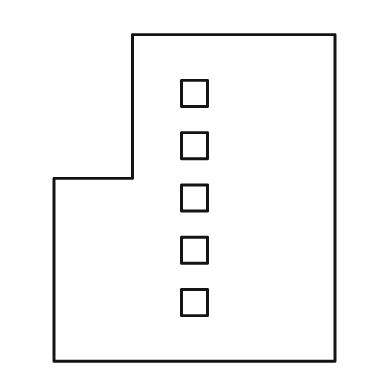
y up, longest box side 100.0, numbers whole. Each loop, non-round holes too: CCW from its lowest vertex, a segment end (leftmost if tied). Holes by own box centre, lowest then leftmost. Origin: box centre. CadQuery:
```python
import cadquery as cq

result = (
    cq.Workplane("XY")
    .moveTo(-43.0, -50.0)
    .lineTo(43.0, -50.0)
    .lineTo(43.0, 50.0)
    .lineTo(-19.0, 50.0)
    .lineTo(-19.0, 6.0)
    .lineTo(-43.0, 6.0)
    .close()
    .moveTo(-4.0, -36.0)
    .lineTo(4.0, -36.0)
    .lineTo(4.0, -28.0)
    .lineTo(-4.0, -28.0)
    .close()
    .moveTo(-4.0, -20.0)
    .lineTo(4.0, -20.0)
    .lineTo(4.0, -12.0)
    .lineTo(-4.0, -12.0)
    .close()
    .moveTo(-4.0, -4.0)
    .lineTo(4.0, -4.0)
    .lineTo(4.0, 4.0)
    .lineTo(-4.0, 4.0)
    .close()
    .moveTo(-4.0, 12.0)
    .lineTo(4.0, 12.0)
    .lineTo(4.0, 20.0)
    .lineTo(-4.0, 20.0)
    .close()
    .moveTo(-4.0, 28.0)
    .lineTo(4.0, 28.0)
    .lineTo(4.0, 36.0)
    .lineTo(-4.0, 36.0)
    .close()
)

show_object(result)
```